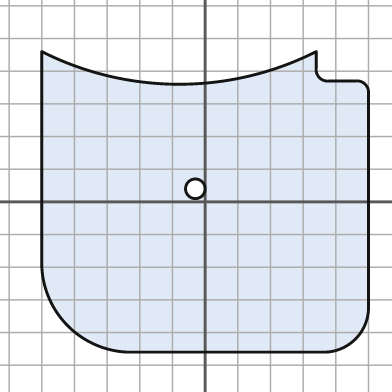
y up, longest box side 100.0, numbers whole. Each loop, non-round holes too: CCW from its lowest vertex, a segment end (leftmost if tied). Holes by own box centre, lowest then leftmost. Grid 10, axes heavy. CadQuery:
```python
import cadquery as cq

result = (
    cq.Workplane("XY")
    .moveTo(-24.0, -46.0)
    .lineTo(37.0, -46.0)
    .threePointArc((46.0, -42.0), (50.0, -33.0))
    .lineTo(50.0, 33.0)
    .threePointArc((49.0, 36.0), (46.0, 37.0))
    .lineTo(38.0, 37.0)
    .threePointArc((35.0, 38.0), (34.0, 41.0))
    .lineTo(34.0, 46.0)
    .threePointArc((-8.0, 36.0), (-50.0, 46.0))
    .lineTo(-50.0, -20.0)
    .threePointArc((-42.0, -38.0), (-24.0, -46.0))
    .close()
    .moveTo(-3.0, 4.0)
    .circle(3.0)
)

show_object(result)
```